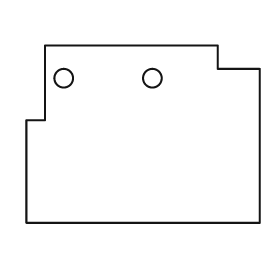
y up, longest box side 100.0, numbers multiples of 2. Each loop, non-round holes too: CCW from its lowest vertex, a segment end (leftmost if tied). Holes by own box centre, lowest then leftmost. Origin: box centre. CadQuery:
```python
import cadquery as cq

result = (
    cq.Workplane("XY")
    .moveTo(-50.0, -38.0)
    .lineTo(50.0, -38.0)
    .lineTo(50.0, 28.0)
    .lineTo(32.0, 28.0)
    .lineTo(32.0, 38.0)
    .lineTo(-42.0, 38.0)
    .lineTo(-42.0, 6.0)
    .lineTo(-50.0, 6.0)
    .close()
    .moveTo(-34.0, 24.0)
    .circle(4.0)
    .moveTo(4.0, 24.0)
    .circle(4.0)
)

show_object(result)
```